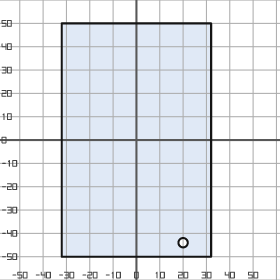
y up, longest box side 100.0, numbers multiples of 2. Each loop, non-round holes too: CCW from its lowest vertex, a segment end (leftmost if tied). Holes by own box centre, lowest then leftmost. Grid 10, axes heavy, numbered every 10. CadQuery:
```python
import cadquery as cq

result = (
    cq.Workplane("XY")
    .moveTo(-32.0, -50.0)
    .lineTo(32.0, -50.0)
    .lineTo(32.0, 50.0)
    .lineTo(-32.0, 50.0)
    .close()
    .moveTo(20.0, -44.0)
    .circle(2.0)
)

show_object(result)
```